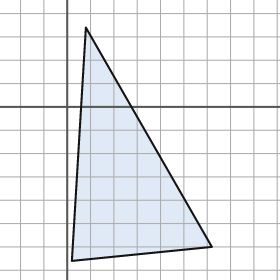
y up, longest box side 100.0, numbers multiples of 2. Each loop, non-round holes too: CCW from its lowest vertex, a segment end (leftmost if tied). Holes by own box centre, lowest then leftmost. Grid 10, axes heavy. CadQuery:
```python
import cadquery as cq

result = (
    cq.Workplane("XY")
    .moveTo(2.0, -66.0)
    .lineTo(62.0, -60.0)
    .lineTo(8.0, 34.0)
    .close()
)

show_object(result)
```